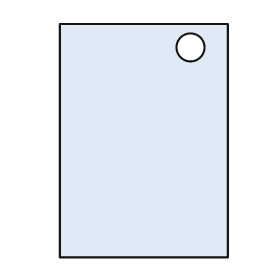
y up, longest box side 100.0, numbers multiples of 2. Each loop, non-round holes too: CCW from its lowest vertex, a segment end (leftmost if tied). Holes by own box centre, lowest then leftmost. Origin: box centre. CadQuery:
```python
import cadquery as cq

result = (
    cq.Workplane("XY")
    .moveTo(-36.0, -50.0)
    .lineTo(36.0, -50.0)
    .lineTo(36.0, 50.0)
    .lineTo(-36.0, 50.0)
    .close()
    .moveTo(20.0, 40.0)
    .circle(6.0)
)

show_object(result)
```